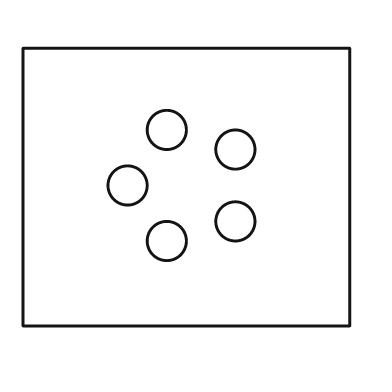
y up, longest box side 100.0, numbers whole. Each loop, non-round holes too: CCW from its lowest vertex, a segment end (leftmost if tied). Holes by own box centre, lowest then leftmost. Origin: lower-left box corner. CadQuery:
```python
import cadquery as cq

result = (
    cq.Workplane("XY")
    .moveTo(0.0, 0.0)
    .lineTo(100.0, 0.0)
    .lineTo(100.0, 85.0)
    .lineTo(0.0, 85.0)
    .close()
    .moveTo(44.0, 26.0)
    .circle(6.0)
    .moveTo(65.0, 32.0)
    .circle(6.0)
    .moveTo(32.0, 43.0)
    .circle(6.0)
    .moveTo(65.0, 54.0)
    .circle(6.0)
    .moveTo(44.0, 60.0)
    .circle(6.0)
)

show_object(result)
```